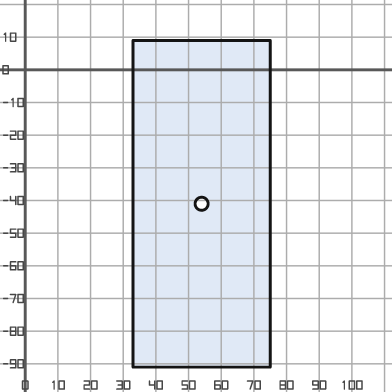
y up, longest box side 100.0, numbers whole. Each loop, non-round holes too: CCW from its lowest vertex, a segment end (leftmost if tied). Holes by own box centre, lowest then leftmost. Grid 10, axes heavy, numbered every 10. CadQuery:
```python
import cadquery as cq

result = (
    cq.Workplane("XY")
    .moveTo(33.0, -91.0)
    .lineTo(75.0, -91.0)
    .lineTo(75.0, 9.0)
    .lineTo(33.0, 9.0)
    .close()
    .moveTo(54.0, -41.0)
    .circle(2.0)
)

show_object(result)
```